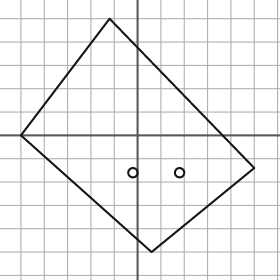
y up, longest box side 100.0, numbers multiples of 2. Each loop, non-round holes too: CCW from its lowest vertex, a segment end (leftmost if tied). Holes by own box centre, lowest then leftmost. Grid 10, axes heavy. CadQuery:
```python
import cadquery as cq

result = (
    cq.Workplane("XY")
    .moveTo(6.0, -50.0)
    .lineTo(50.0, -14.0)
    .lineTo(-12.0, 50.0)
    .lineTo(-50.0, 0.0)
    .close()
    .moveTo(-2.0, -16.0)
    .circle(2.0)
    .moveTo(18.0, -16.0)
    .circle(2.0)
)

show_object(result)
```